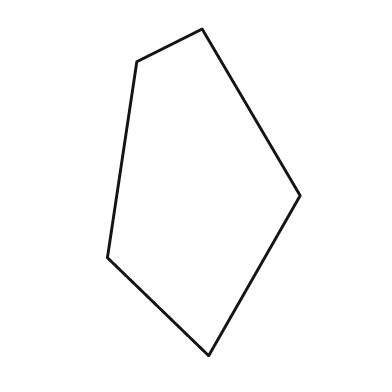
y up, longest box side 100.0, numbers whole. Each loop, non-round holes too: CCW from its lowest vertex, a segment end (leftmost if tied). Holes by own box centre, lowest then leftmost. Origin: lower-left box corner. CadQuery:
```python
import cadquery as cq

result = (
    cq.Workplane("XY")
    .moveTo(31.0, 0.0)
    .lineTo(59.0, 49.0)
    .lineTo(29.0, 100.0)
    .lineTo(9.0, 90.0)
    .lineTo(0.0, 30.0)
    .close()
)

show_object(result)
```